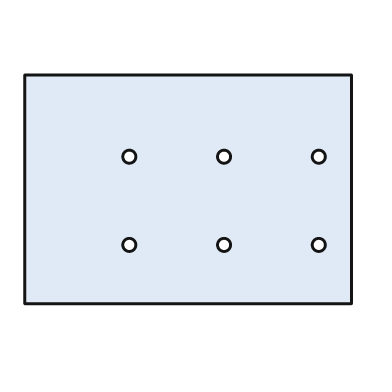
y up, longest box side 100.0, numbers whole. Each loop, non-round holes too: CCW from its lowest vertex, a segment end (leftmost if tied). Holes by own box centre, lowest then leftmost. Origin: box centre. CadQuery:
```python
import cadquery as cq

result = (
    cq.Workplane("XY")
    .moveTo(-50.0, -35.0)
    .lineTo(50.0, -35.0)
    .lineTo(50.0, 35.0)
    .lineTo(-50.0, 35.0)
    .close()
    .moveTo(-18.0, -17.0)
    .circle(2.0)
    .moveTo(11.0, -17.0)
    .circle(2.0)
    .moveTo(40.0, -17.0)
    .circle(2.0)
    .moveTo(-18.0, 10.0)
    .circle(2.0)
    .moveTo(11.0, 10.0)
    .circle(2.0)
    .moveTo(40.0, 10.0)
    .circle(2.0)
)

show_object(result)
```